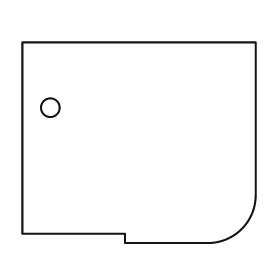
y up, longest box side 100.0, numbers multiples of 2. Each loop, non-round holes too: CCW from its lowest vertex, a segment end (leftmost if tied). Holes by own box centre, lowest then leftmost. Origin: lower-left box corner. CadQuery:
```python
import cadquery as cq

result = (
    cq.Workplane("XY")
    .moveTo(44.0, 0.0)
    .lineTo(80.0, 0.0)
    .threePointArc((94.0, 6.0), (100.0, 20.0))
    .lineTo(100.0, 86.0)
    .lineTo(0.0, 86.0)
    .lineTo(0.0, 4.0)
    .lineTo(44.0, 4.0)
    .close()
    .moveTo(12.0, 58.0)
    .circle(4.0)
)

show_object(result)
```